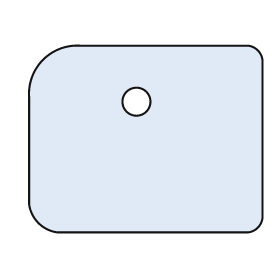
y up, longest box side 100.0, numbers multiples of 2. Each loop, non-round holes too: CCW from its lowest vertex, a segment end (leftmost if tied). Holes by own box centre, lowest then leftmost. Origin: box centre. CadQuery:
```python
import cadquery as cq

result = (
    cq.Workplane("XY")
    .moveTo(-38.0, -40.0)
    .lineTo(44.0, -40.0)
    .threePointArc((48.0, -38.0), (50.0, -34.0))
    .lineTo(50.0, 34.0)
    .threePointArc((48.0, 38.0), (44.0, 40.0))
    .lineTo(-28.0, 40.0)
    .threePointArc((-44.0, 34.0), (-50.0, 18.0))
    .lineTo(-50.0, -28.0)
    .threePointArc((-46.0, -36.0), (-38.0, -40.0))
    .close()
    .moveTo(-4.0, 16.0)
    .circle(6.0)
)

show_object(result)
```